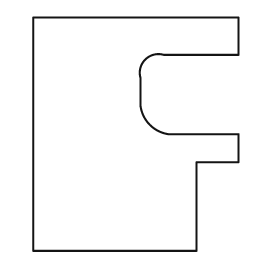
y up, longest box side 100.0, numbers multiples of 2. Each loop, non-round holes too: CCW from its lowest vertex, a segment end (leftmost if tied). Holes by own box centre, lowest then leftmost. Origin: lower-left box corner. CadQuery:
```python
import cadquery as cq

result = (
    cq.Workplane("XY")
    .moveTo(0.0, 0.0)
    .lineTo(70.0, 0.0)
    .lineTo(70.0, 38.0)
    .lineTo(88.0, 38.0)
    .lineTo(88.0, 50.0)
    .lineTo(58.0, 50.0)
    .threePointArc((50.0, 54.0), (46.0, 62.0))
    .lineTo(46.0, 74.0)
    .threePointArc((48.0, 82.0), (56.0, 84.0))
    .lineTo(88.0, 84.0)
    .lineTo(88.0, 100.0)
    .lineTo(0.0, 100.0)
    .close()
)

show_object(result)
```